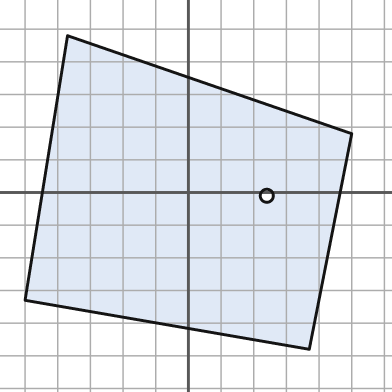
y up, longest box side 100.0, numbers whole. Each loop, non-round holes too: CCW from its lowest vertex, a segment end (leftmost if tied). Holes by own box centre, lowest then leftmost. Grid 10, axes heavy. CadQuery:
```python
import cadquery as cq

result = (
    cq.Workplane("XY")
    .moveTo(37.0, -48.0)
    .lineTo(50.0, 18.0)
    .lineTo(-37.0, 48.0)
    .lineTo(-50.0, -33.0)
    .close()
    .moveTo(24.0, -1.0)
    .circle(2.0)
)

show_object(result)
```